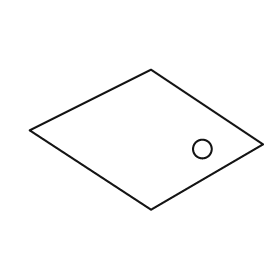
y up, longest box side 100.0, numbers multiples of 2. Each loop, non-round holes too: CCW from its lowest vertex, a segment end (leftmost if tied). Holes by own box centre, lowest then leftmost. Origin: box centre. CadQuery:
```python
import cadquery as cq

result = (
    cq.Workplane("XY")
    .moveTo(2.0, -30.0)
    .lineTo(50.0, -2.0)
    .lineTo(2.0, 30.0)
    .lineTo(-50.0, 4.0)
    .close()
    .moveTo(24.0, -4.0)
    .circle(4.0)
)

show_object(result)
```